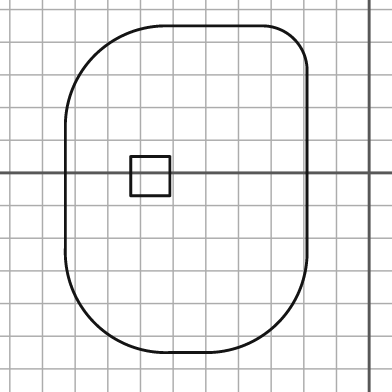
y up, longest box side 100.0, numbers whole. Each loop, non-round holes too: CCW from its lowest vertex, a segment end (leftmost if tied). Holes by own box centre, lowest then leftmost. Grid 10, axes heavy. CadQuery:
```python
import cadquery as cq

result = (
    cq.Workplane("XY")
    .moveTo(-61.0, -55.0)
    .lineTo(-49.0, -55.0)
    .threePointArc((-28.0, -46.0), (-19.0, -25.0))
    .lineTo(-19.0, 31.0)
    .threePointArc((-23.0, 41.0), (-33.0, 45.0))
    .lineTo(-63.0, 45.0)
    .threePointArc((-84.0, 36.0), (-93.0, 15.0))
    .lineTo(-93.0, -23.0)
    .threePointArc((-84.0, -46.0), (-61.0, -55.0))
    .close()
    .moveTo(-73.0, -7.0)
    .lineTo(-61.0, -7.0)
    .lineTo(-61.0, 5.0)
    .lineTo(-73.0, 5.0)
    .close()
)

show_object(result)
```